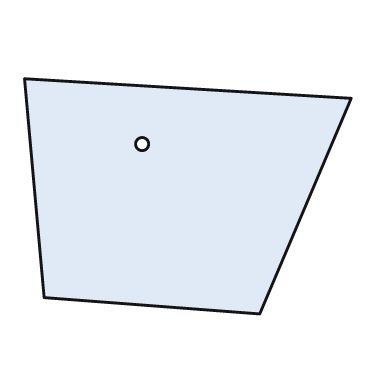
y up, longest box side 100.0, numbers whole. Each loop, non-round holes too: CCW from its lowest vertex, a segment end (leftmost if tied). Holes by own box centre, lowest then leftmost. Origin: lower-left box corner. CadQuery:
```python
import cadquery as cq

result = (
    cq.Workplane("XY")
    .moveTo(72.0, 0.0)
    .lineTo(100.0, 66.0)
    .lineTo(0.0, 72.0)
    .lineTo(6.0, 5.0)
    .close()
    .moveTo(36.0, 52.0)
    .circle(2.0)
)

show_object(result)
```